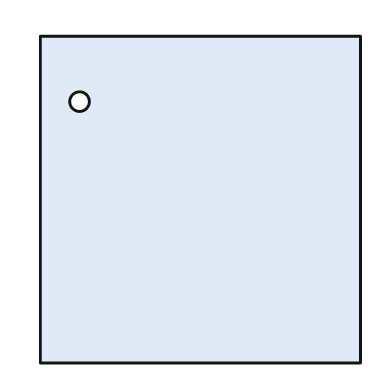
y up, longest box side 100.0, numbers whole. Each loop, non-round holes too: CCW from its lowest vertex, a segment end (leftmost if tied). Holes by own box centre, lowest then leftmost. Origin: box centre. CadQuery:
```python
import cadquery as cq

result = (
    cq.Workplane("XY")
    .moveTo(-49.0, -50.0)
    .lineTo(49.0, -50.0)
    .lineTo(49.0, 50.0)
    .lineTo(-49.0, 50.0)
    .close()
    .moveTo(-37.0, 30.0)
    .circle(3.0)
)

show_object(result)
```